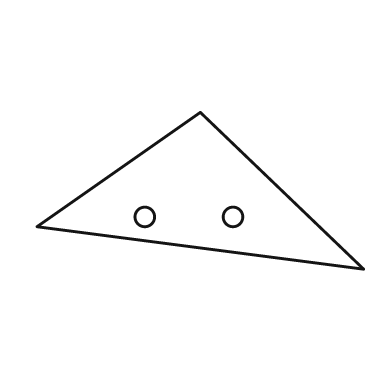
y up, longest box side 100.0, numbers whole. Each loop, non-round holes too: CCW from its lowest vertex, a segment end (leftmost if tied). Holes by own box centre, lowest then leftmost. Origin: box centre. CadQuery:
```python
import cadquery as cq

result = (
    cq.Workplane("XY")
    .moveTo(50.0, -24.0)
    .lineTo(0.0, 24.0)
    .lineTo(-50.0, -11.0)
    .close()
    .moveTo(-17.0, -8.0)
    .circle(3.0)
    .moveTo(10.0, -8.0)
    .circle(3.0)
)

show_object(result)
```